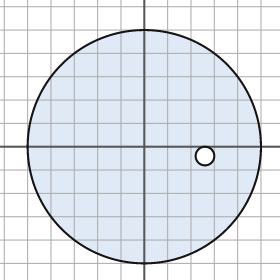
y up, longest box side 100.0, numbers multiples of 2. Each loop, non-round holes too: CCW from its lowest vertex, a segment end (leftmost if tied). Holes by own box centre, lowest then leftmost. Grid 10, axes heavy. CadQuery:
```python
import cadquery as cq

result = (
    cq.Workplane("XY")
    .moveTo(0.0, 0.0)
    .circle(50.0)
    .moveTo(26.0, -4.0)
    .circle(4.0)
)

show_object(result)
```